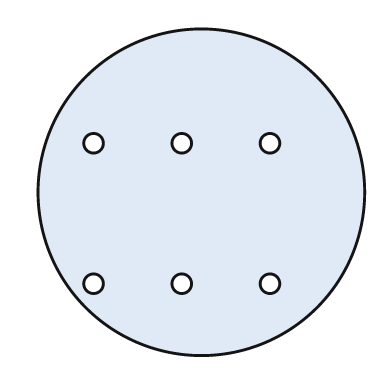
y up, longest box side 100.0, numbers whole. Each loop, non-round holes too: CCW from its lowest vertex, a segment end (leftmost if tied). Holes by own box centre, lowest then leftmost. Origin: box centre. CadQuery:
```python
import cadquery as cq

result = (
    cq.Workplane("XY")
    .moveTo(0.0, 0.0)
    .circle(50.0)
    .moveTo(-33.0, -28.0)
    .circle(3.0)
    .moveTo(-6.0, -28.0)
    .circle(3.0)
    .moveTo(21.0, -28.0)
    .circle(3.0)
    .moveTo(-33.0, 15.0)
    .circle(3.0)
    .moveTo(-6.0, 15.0)
    .circle(3.0)
    .moveTo(21.0, 15.0)
    .circle(3.0)
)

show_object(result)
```